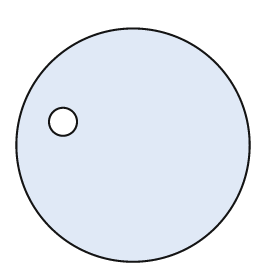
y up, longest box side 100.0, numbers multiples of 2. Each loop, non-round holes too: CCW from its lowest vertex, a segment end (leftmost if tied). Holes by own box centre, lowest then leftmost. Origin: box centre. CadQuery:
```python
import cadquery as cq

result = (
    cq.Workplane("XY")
    .moveTo(0.0, 0.0)
    .circle(50.0)
    .moveTo(-30.0, 10.0)
    .circle(6.0)
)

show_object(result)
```